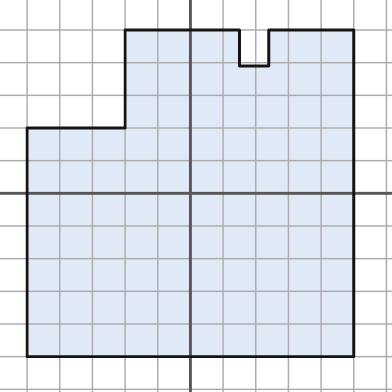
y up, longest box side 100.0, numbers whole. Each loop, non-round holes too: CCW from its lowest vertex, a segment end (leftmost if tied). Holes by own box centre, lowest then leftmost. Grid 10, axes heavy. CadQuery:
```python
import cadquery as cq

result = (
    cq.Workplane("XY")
    .moveTo(-50.0, -50.0)
    .lineTo(50.0, -50.0)
    .lineTo(50.0, 50.0)
    .lineTo(24.0, 50.0)
    .lineTo(24.0, 39.0)
    .lineTo(15.0, 39.0)
    .lineTo(15.0, 50.0)
    .lineTo(-20.0, 50.0)
    .lineTo(-20.0, 20.0)
    .lineTo(-50.0, 20.0)
    .close()
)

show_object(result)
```